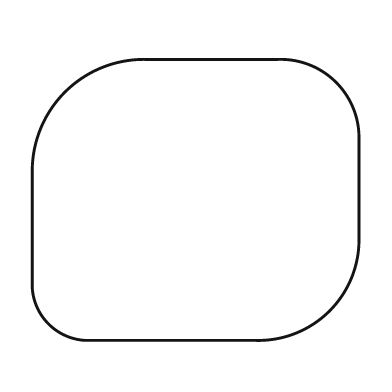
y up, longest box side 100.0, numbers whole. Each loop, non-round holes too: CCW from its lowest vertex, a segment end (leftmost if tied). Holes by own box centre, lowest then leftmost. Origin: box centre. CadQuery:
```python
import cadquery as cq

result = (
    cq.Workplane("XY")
    .moveTo(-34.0, -43.0)
    .lineTo(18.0, -43.0)
    .threePointArc((41.0, -34.0), (50.0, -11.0))
    .lineTo(50.0, 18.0)
    .threePointArc((43.0, 36.0), (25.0, 43.0))
    .lineTo(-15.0, 43.0)
    .threePointArc((-40.0, 33.0), (-50.0, 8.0))
    .lineTo(-50.0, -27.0)
    .threePointArc((-45.0, -38.0), (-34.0, -43.0))
    .close()
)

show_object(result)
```